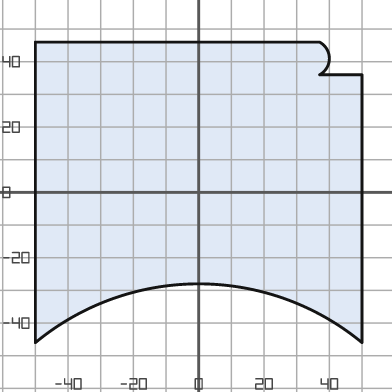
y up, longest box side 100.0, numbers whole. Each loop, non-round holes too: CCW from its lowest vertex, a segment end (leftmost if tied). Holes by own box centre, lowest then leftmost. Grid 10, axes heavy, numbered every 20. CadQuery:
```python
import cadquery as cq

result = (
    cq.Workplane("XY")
    .moveTo(-50.0, -46.0)
    .threePointArc((0.0, -28.0), (50.0, -46.0))
    .lineTo(50.0, 36.0)
    .lineTo(37.0, 36.0)
    .threePointArc((40.0, 41.0), (37.0, 46.0))
    .lineTo(-50.0, 46.0)
    .close()
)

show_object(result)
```